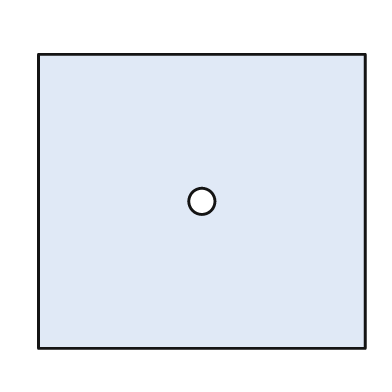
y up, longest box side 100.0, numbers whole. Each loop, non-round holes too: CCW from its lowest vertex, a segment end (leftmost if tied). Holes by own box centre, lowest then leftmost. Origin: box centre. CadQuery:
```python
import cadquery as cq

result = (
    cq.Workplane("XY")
    .moveTo(-50.0, -45.0)
    .lineTo(50.0, -45.0)
    .lineTo(50.0, 45.0)
    .lineTo(-50.0, 45.0)
    .close()
    .moveTo(0.0, 0.0)
    .circle(4.0)
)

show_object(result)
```